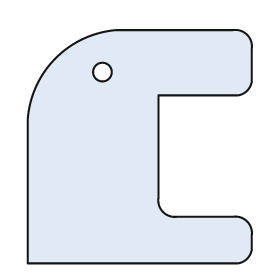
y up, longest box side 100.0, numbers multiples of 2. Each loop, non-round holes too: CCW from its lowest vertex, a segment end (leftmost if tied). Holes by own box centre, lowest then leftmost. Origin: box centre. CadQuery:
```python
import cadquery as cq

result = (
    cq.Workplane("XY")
    .moveTo(-48.0, -50.0)
    .lineTo(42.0, -50.0)
    .threePointArc((46.0, -48.0), (48.0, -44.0))
    .lineTo(48.0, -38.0)
    .threePointArc((46.0, -32.0), (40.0, -30.0))
    .lineTo(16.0, -30.0)
    .threePointArc((10.0, -28.0), (8.0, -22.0))
    .lineTo(8.0, 22.0)
    .lineTo(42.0, 22.0)
    .threePointArc((46.0, 24.0), (48.0, 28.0))
    .lineTo(48.0, 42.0)
    .threePointArc((46.0, 48.0), (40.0, 50.0))
    .lineTo(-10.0, 50.0)
    .threePointArc((-36.0, 38.0), (-48.0, 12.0))
    .close()
    .moveTo(-16.0, 32.0)
    .circle(4.0)
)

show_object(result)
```